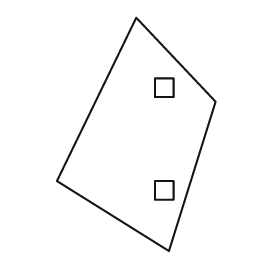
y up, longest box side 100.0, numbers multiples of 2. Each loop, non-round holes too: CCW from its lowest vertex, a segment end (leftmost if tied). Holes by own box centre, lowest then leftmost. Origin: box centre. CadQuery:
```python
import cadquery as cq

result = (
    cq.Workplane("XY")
    .moveTo(14.0, -50.0)
    .lineTo(34.0, 14.0)
    .lineTo(0.0, 50.0)
    .lineTo(-34.0, -20.0)
    .close()
    .moveTo(8.0, -28.0)
    .lineTo(16.0, -28.0)
    .lineTo(16.0, -20.0)
    .lineTo(8.0, -20.0)
    .close()
    .moveTo(8.0, 16.0)
    .lineTo(16.0, 16.0)
    .lineTo(16.0, 24.0)
    .lineTo(8.0, 24.0)
    .close()
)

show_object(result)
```